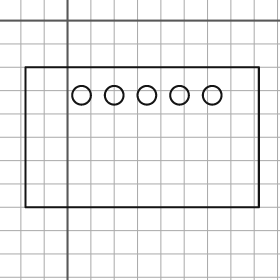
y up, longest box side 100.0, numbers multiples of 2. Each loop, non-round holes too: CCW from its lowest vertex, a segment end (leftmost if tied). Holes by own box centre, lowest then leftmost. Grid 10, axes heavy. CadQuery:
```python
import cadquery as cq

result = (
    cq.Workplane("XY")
    .moveTo(-18.0, -80.0)
    .lineTo(82.0, -80.0)
    .lineTo(82.0, -20.0)
    .lineTo(-18.0, -20.0)
    .close()
    .moveTo(6.0, -32.0)
    .circle(4.0)
    .moveTo(20.0, -32.0)
    .circle(4.0)
    .moveTo(34.0, -32.0)
    .circle(4.0)
    .moveTo(48.0, -32.0)
    .circle(4.0)
    .moveTo(62.0, -32.0)
    .circle(4.0)
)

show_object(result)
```